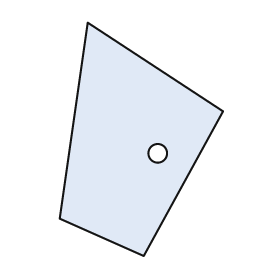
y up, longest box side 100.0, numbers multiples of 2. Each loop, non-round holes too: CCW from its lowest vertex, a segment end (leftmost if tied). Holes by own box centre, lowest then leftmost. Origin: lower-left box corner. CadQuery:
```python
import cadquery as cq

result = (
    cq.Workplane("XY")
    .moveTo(36.0, 0.0)
    .lineTo(70.0, 62.0)
    .lineTo(12.0, 100.0)
    .lineTo(0.0, 16.0)
    .close()
    .moveTo(42.0, 44.0)
    .circle(4.0)
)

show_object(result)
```